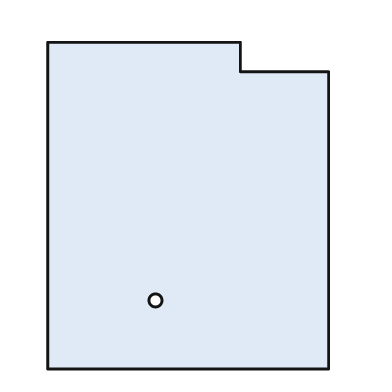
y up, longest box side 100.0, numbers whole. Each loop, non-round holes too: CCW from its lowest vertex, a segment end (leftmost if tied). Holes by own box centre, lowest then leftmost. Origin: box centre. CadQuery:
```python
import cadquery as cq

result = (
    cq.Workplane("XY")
    .moveTo(-43.0, -50.0)
    .lineTo(43.0, -50.0)
    .lineTo(43.0, 41.0)
    .lineTo(16.0, 41.0)
    .lineTo(16.0, 50.0)
    .lineTo(-43.0, 50.0)
    .close()
    .moveTo(-10.0, -29.0)
    .circle(2.0)
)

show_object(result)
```